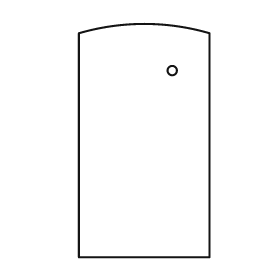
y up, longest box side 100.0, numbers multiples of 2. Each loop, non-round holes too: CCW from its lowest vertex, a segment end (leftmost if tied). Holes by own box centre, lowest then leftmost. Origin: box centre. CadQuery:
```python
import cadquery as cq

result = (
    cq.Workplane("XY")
    .moveTo(-28.0, -50.0)
    .lineTo(28.0, -50.0)
    .lineTo(28.0, 46.0)
    .threePointArc((0.0, 50.0), (-28.0, 46.0))
    .close()
    .moveTo(12.0, 30.0)
    .circle(2.0)
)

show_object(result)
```